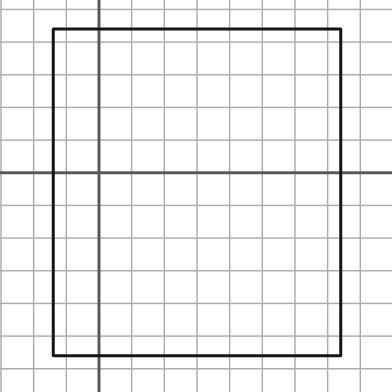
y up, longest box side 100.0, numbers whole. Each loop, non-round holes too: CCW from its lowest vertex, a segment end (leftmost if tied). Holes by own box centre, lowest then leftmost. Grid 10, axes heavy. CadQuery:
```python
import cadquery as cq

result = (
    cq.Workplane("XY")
    .moveTo(-14.0, -56.0)
    .lineTo(74.0, -56.0)
    .lineTo(74.0, 44.0)
    .lineTo(-14.0, 44.0)
    .close()
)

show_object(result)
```